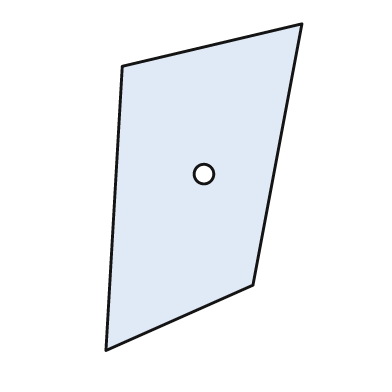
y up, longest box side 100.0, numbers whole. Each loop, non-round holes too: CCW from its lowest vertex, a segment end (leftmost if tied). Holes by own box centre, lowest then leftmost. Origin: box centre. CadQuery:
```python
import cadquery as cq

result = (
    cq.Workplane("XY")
    .moveTo(-30.0, -50.0)
    .lineTo(15.0, -30.0)
    .lineTo(30.0, 50.0)
    .lineTo(-25.0, 37.0)
    .close()
    .moveTo(0.0, 4.0)
    .circle(3.0)
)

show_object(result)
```